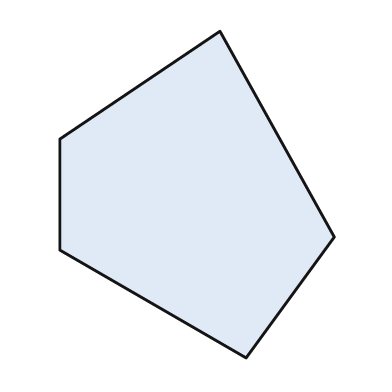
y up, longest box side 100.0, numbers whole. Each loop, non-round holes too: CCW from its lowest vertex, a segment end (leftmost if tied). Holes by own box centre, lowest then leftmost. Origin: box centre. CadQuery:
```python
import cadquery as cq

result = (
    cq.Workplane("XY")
    .moveTo(15.0, -50.0)
    .lineTo(42.0, -13.0)
    .lineTo(7.0, 50.0)
    .lineTo(-42.0, 17.0)
    .lineTo(-42.0, -17.0)
    .close()
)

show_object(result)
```